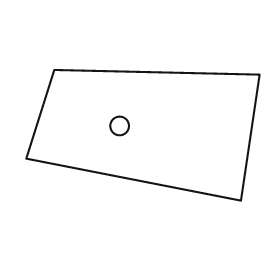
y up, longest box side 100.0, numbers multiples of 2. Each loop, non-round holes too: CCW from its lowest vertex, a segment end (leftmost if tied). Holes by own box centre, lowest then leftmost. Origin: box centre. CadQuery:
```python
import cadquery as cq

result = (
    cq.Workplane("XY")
    .moveTo(42.0, -28.0)
    .lineTo(50.0, 26.0)
    .lineTo(-38.0, 28.0)
    .lineTo(-50.0, -10.0)
    .close()
    .moveTo(-10.0, 4.0)
    .circle(4.0)
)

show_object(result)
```